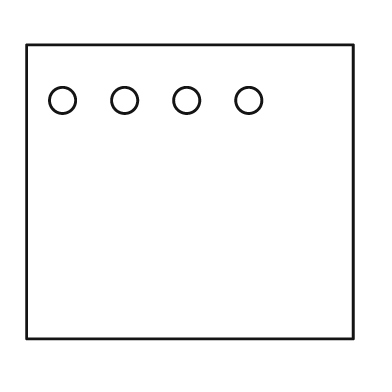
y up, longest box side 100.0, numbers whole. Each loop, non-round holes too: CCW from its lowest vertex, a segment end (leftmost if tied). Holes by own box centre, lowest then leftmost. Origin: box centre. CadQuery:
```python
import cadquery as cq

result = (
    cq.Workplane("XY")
    .moveTo(-50.0, -45.0)
    .lineTo(50.0, -45.0)
    .lineTo(50.0, 45.0)
    .lineTo(-50.0, 45.0)
    .close()
    .moveTo(-39.0, 28.0)
    .circle(4.0)
    .moveTo(-20.0, 28.0)
    .circle(4.0)
    .moveTo(-1.0, 28.0)
    .circle(4.0)
    .moveTo(18.0, 28.0)
    .circle(4.0)
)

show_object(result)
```